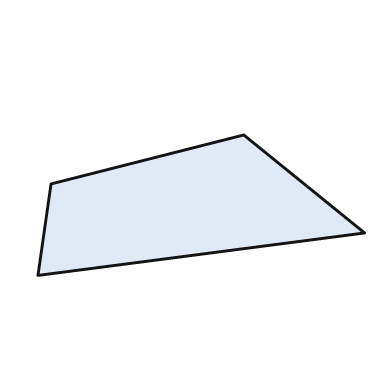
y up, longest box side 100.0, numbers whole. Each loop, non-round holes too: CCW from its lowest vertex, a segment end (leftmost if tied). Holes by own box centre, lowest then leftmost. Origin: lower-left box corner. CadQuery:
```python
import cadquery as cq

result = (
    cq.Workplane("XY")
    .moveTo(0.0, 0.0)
    .lineTo(100.0, 13.0)
    .lineTo(63.0, 43.0)
    .lineTo(4.0, 28.0)
    .close()
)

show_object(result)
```